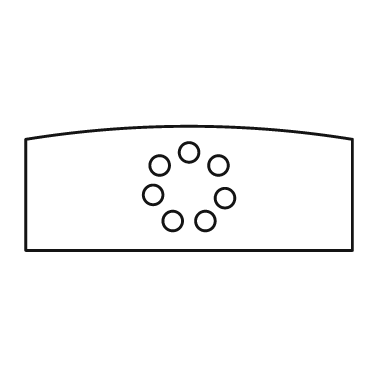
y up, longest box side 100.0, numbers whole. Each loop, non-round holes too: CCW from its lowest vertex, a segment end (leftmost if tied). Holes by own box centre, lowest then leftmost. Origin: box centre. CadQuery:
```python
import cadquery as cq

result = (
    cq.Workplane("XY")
    .moveTo(-50.0, -19.0)
    .lineTo(50.0, -19.0)
    .lineTo(50.0, 15.0)
    .threePointArc((0.0, 19.0), (-50.0, 15.0))
    .close()
    .moveTo(-5.0, -10.0)
    .circle(3.0)
    .moveTo(5.0, -10.0)
    .circle(3.0)
    .moveTo(11.0, -3.0)
    .circle(3.0)
    .moveTo(-11.0, -2.0)
    .circle(3.0)
    .moveTo(-9.0, 7.0)
    .circle(3.0)
    .moveTo(9.0, 7.0)
    .circle(3.0)
    .moveTo(0.0, 11.0)
    .circle(3.0)
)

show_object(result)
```